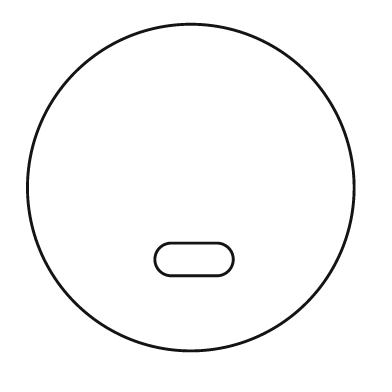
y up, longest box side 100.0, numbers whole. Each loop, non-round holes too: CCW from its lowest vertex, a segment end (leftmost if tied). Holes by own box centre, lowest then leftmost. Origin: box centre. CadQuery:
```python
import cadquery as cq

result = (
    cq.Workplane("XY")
    .moveTo(0.0, 0.0)
    .circle(50.0)
    .moveTo(-6.0, -27.0)
    .lineTo(8.0, -27.0)
    .threePointArc((13.0, -22.0), (8.0, -17.0))
    .lineTo(-6.0, -17.0)
    .threePointArc((-11.0, -22.0), (-6.0, -27.0))
    .close()
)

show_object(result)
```